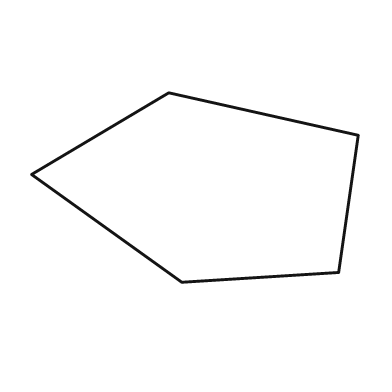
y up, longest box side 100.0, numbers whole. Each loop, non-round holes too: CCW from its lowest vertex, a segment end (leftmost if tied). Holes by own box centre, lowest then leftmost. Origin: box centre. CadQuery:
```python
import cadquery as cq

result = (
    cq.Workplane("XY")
    .moveTo(-4.0, -29.0)
    .lineTo(44.0, -26.0)
    .lineTo(50.0, 16.0)
    .lineTo(-8.0, 29.0)
    .lineTo(-50.0, 4.0)
    .close()
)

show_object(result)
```